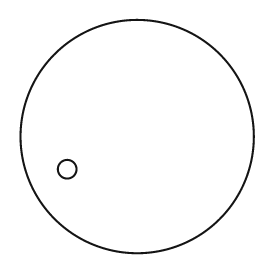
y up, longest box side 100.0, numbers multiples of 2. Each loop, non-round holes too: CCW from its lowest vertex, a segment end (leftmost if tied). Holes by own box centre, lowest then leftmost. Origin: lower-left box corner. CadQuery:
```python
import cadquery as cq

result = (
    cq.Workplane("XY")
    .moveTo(50.0, 50.0)
    .circle(50.0)
    .moveTo(20.0, 36.0)
    .circle(4.0)
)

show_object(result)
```